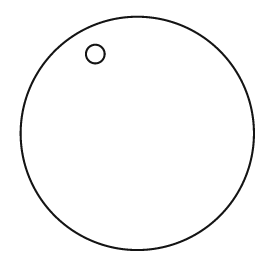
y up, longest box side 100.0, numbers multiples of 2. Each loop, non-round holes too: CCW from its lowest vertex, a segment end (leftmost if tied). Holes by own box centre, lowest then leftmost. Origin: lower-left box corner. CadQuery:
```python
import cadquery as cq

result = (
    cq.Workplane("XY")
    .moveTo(50.0, 50.0)
    .circle(50.0)
    .moveTo(32.0, 84.0)
    .circle(4.0)
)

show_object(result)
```